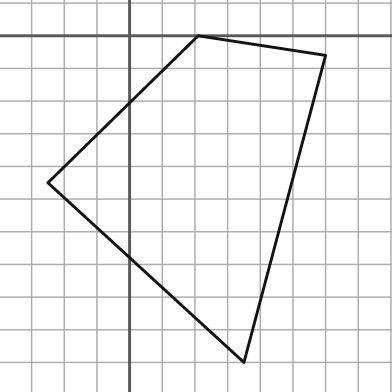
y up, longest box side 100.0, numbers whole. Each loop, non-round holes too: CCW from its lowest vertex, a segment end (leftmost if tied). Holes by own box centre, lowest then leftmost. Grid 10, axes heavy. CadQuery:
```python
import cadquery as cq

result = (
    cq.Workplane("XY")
    .moveTo(35.0, -100.0)
    .lineTo(60.0, -6.0)
    .lineTo(21.0, 0.0)
    .lineTo(-25.0, -45.0)
    .close()
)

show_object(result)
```